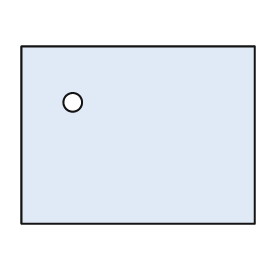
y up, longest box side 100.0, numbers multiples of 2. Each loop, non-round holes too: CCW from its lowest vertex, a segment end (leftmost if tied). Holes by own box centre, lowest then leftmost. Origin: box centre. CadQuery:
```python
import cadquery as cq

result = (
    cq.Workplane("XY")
    .moveTo(-50.0, -38.0)
    .lineTo(50.0, -38.0)
    .lineTo(50.0, 38.0)
    .lineTo(-50.0, 38.0)
    .close()
    .moveTo(-28.0, 14.0)
    .circle(4.0)
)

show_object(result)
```